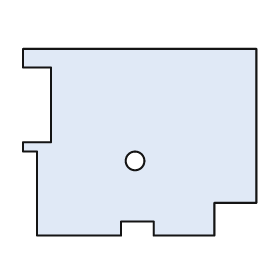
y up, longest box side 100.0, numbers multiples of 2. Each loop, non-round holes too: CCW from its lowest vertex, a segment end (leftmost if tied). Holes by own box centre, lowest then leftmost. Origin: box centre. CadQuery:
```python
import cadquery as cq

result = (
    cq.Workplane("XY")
    .moveTo(-44.0, -40.0)
    .lineTo(-8.0, -40.0)
    .lineTo(-8.0, -34.0)
    .lineTo(6.0, -34.0)
    .lineTo(6.0, -40.0)
    .lineTo(32.0, -40.0)
    .lineTo(32.0, -26.0)
    .lineTo(50.0, -26.0)
    .lineTo(50.0, 40.0)
    .lineTo(-50.0, 40.0)
    .lineTo(-50.0, 32.0)
    .lineTo(-38.0, 32.0)
    .lineTo(-38.0, 0.0)
    .lineTo(-50.0, 0.0)
    .lineTo(-50.0, -4.0)
    .lineTo(-44.0, -4.0)
    .close()
    .moveTo(-2.0, -8.0)
    .circle(4.0)
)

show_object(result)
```